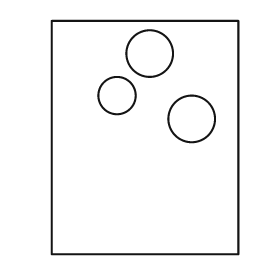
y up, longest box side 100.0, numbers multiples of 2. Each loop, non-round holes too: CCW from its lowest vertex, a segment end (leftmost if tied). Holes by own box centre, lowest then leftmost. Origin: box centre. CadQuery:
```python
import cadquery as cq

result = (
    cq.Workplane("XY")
    .moveTo(-40.0, -50.0)
    .lineTo(40.0, -50.0)
    .lineTo(40.0, 50.0)
    .lineTo(-40.0, 50.0)
    .close()
    .moveTo(20.0, 8.0)
    .circle(10.0)
    .moveTo(-12.0, 18.0)
    .circle(8.0)
    .moveTo(2.0, 36.0)
    .circle(10.0)
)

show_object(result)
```